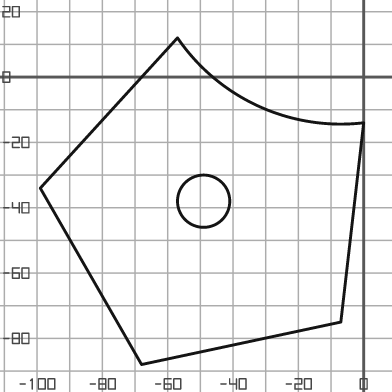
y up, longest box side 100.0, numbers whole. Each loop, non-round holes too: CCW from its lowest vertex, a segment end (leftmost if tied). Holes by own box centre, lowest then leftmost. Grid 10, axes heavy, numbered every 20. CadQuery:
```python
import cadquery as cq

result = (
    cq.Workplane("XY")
    .moveTo(-68.0, -88.0)
    .lineTo(-7.0, -75.0)
    .lineTo(0.0, -14.0)
    .threePointArc((-32.0, -9.0), (-57.0, 12.0))
    .lineTo(-99.0, -34.0)
    .close()
    .moveTo(-49.0, -38.0)
    .circle(8.0)
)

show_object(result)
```